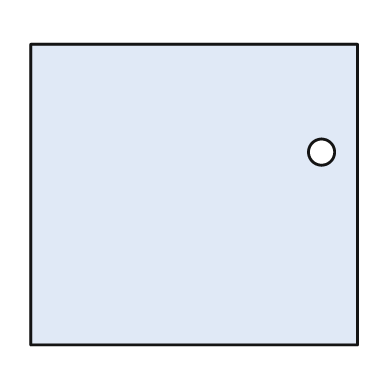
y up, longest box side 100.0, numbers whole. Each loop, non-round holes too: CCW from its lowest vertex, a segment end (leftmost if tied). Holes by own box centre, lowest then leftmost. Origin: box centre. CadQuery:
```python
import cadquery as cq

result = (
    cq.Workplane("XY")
    .moveTo(-50.0, -46.0)
    .lineTo(50.0, -46.0)
    .lineTo(50.0, 46.0)
    .lineTo(-50.0, 46.0)
    .close()
    .moveTo(39.0, 13.0)
    .circle(4.0)
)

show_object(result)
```